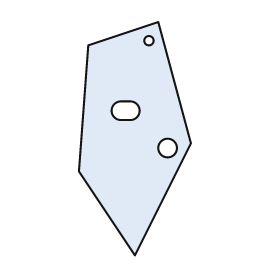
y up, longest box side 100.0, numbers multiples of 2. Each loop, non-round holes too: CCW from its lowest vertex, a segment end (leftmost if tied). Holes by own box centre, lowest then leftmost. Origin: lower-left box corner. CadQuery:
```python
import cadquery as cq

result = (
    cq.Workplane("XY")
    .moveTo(24.0, 0.0)
    .lineTo(48.0, 48.0)
    .lineTo(34.0, 100.0)
    .lineTo(4.0, 90.0)
    .lineTo(0.0, 36.0)
    .close()
    .moveTo(38.0, 46.0)
    .circle(4.0)
    .moveTo(18.0, 58.0)
    .lineTo(22.0, 58.0)
    .threePointArc((26.0, 62.0), (22.0, 66.0))
    .lineTo(18.0, 66.0)
    .threePointArc((14.0, 62.0), (18.0, 58.0))
    .close()
    .moveTo(30.0, 92.0)
    .circle(2.0)
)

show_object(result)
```